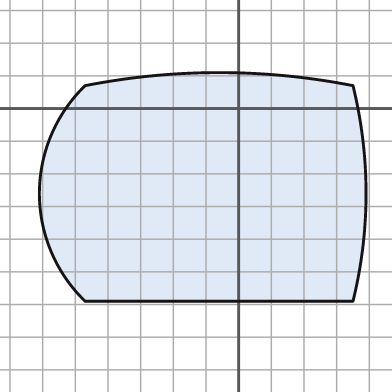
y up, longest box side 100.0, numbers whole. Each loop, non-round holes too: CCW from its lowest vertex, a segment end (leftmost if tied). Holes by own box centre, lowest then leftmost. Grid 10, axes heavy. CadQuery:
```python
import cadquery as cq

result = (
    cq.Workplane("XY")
    .moveTo(-47.0, -59.0)
    .lineTo(35.0, -59.0)
    .threePointArc((39.0, -26.0), (35.0, 7.0))
    .threePointArc((-6.0, 11.0), (-47.0, 7.0))
    .threePointArc((-61.0, -26.0), (-47.0, -59.0))
    .close()
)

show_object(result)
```